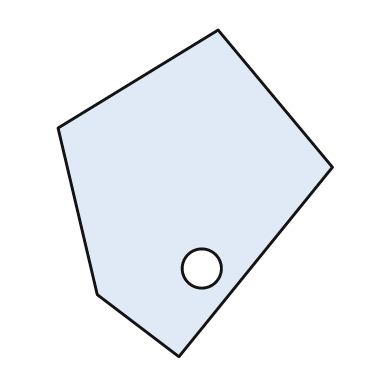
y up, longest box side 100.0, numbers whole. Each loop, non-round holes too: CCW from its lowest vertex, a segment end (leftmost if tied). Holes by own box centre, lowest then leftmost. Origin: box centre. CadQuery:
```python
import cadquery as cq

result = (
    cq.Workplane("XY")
    .moveTo(-5.0, -50.0)
    .lineTo(42.0, 8.0)
    .lineTo(7.0, 50.0)
    .lineTo(-42.0, 20.0)
    .lineTo(-30.0, -31.0)
    .close()
    .moveTo(2.0, -23.0)
    .circle(6.0)
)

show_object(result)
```